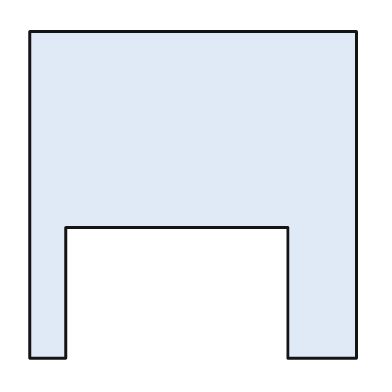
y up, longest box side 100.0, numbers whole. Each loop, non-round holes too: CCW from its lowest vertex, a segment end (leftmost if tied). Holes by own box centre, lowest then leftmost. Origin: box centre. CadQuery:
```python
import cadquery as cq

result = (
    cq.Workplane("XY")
    .moveTo(-50.0, -50.0)
    .lineTo(-39.0, -50.0)
    .lineTo(-39.0, -10.0)
    .lineTo(29.0, -10.0)
    .lineTo(29.0, -50.0)
    .lineTo(50.0, -50.0)
    .lineTo(50.0, 50.0)
    .lineTo(-50.0, 50.0)
    .close()
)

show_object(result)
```